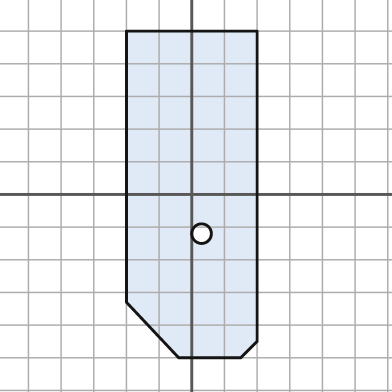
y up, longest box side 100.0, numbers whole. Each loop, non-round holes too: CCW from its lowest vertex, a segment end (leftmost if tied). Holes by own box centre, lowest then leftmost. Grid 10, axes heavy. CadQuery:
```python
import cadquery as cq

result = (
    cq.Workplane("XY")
    .moveTo(-4.0, -50.0)
    .lineTo(15.0, -50.0)
    .lineTo(20.0, -45.0)
    .lineTo(20.0, 50.0)
    .lineTo(-20.0, 50.0)
    .lineTo(-20.0, -33.0)
    .close()
    .moveTo(3.0, -12.0)
    .circle(3.0)
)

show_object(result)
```